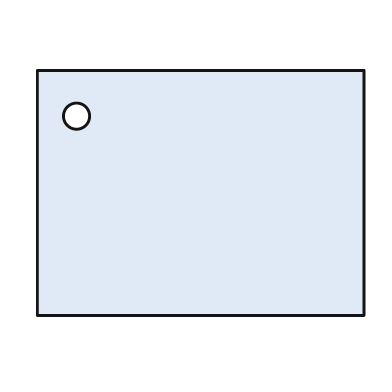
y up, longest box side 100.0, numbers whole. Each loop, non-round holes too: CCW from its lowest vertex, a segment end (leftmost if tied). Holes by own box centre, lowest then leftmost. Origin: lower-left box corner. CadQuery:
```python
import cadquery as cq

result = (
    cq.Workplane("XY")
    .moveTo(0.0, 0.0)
    .lineTo(100.0, 0.0)
    .lineTo(100.0, 75.0)
    .lineTo(0.0, 75.0)
    .close()
    .moveTo(12.0, 61.0)
    .circle(4.0)
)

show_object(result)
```